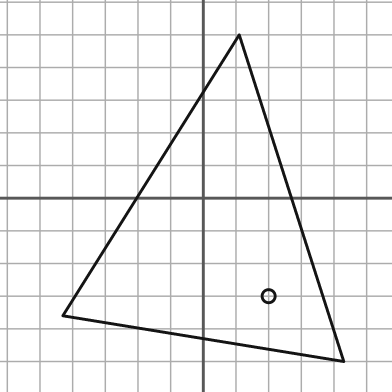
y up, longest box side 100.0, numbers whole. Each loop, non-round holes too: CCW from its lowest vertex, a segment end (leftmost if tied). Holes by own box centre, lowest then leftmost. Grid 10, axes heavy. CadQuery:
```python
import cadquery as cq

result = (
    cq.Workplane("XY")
    .moveTo(43.0, -50.0)
    .lineTo(11.0, 50.0)
    .lineTo(-43.0, -36.0)
    .close()
    .moveTo(20.0, -30.0)
    .circle(2.0)
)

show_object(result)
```